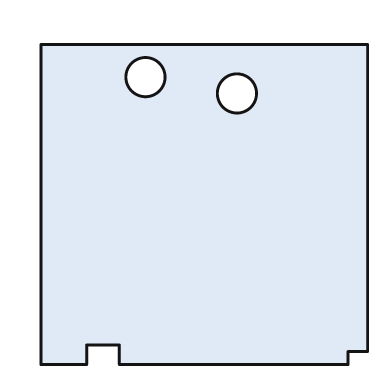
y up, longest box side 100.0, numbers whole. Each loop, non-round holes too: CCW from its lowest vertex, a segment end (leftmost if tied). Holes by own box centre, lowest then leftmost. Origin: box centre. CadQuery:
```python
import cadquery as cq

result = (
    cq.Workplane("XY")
    .moveTo(-50.0, -49.0)
    .lineTo(-36.0, -49.0)
    .lineTo(-36.0, -43.0)
    .lineTo(-26.0, -43.0)
    .lineTo(-26.0, -49.0)
    .lineTo(44.0, -49.0)
    .lineTo(44.0, -45.0)
    .lineTo(50.0, -45.0)
    .lineTo(50.0, 49.0)
    .lineTo(-50.0, 49.0)
    .close()
    .moveTo(10.0, 34.0)
    .circle(6.0)
    .moveTo(-18.0, 39.0)
    .circle(6.0)
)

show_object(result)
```